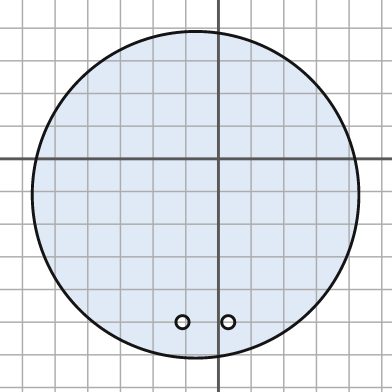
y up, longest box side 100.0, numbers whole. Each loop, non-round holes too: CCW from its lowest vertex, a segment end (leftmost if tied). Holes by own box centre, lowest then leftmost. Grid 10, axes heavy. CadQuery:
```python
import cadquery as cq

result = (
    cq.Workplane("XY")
    .moveTo(-7.0, -11.0)
    .circle(50.0)
    .moveTo(-11.0, -50.0)
    .circle(2.0)
    .moveTo(3.0, -50.0)
    .circle(2.0)
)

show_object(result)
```